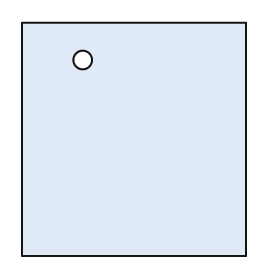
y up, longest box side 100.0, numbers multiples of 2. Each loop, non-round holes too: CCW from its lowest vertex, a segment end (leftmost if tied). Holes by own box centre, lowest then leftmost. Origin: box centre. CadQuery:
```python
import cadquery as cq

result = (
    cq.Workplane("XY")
    .moveTo(-48.0, -50.0)
    .lineTo(48.0, -50.0)
    .lineTo(48.0, 50.0)
    .lineTo(-48.0, 50.0)
    .close()
    .moveTo(-22.0, 34.0)
    .circle(4.0)
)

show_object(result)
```